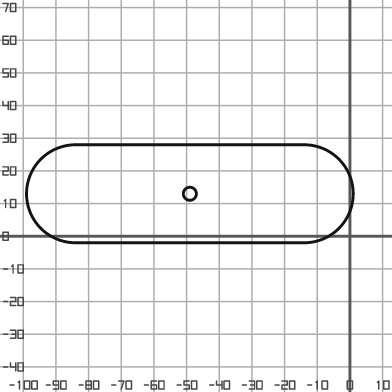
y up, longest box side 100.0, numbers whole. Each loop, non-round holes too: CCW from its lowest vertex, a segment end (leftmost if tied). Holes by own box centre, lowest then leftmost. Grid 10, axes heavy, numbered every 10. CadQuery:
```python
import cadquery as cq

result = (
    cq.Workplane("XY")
    .moveTo(-84.0, -2.0)
    .lineTo(-14.0, -2.0)
    .threePointArc((1.0, 13.0), (-14.0, 28.0))
    .lineTo(-84.0, 28.0)
    .threePointArc((-99.0, 13.0), (-84.0, -2.0))
    .close()
    .moveTo(-49.0, 13.0)
    .circle(2.0)
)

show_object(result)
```